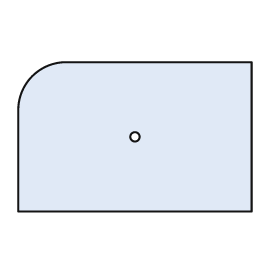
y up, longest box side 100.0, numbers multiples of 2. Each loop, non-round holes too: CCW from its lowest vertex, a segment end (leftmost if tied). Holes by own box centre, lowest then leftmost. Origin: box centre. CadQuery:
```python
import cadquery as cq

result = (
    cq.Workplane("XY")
    .moveTo(-50.0, -32.0)
    .lineTo(50.0, -32.0)
    .lineTo(50.0, 32.0)
    .lineTo(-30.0, 32.0)
    .threePointArc((-44.0, 26.0), (-50.0, 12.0))
    .close()
    .moveTo(0.0, 0.0)
    .circle(2.0)
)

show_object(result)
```